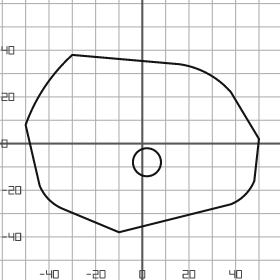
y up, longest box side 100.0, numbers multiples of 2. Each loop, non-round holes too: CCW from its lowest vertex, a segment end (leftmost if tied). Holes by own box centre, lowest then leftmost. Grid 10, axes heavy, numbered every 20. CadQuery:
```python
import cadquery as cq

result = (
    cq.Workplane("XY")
    .moveTo(-10.0, -38.0)
    .lineTo(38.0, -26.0)
    .threePointArc((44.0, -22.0), (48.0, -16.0))
    .lineTo(50.0, 2.0)
    .lineTo(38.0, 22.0)
    .threePointArc((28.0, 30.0), (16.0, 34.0))
    .lineTo(-30.0, 38.0)
    .threePointArc((-42.0, 24.0), (-50.0, 8.0))
    .lineTo(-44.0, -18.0)
    .threePointArc((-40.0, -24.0), (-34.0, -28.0))
    .close()
    .moveTo(2.0, -8.0)
    .circle(6.0)
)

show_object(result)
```